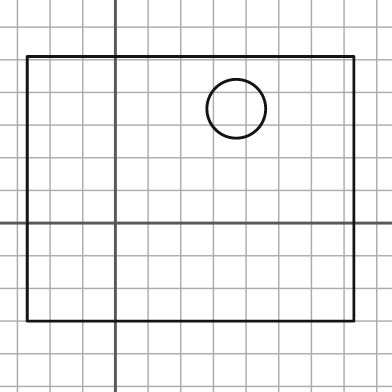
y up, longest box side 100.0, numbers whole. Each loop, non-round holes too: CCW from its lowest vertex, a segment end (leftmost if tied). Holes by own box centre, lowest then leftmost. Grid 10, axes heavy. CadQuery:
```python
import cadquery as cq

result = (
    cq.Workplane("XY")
    .moveTo(-27.0, -30.0)
    .lineTo(73.0, -30.0)
    .lineTo(73.0, 51.0)
    .lineTo(-27.0, 51.0)
    .close()
    .moveTo(37.0, 35.0)
    .circle(9.0)
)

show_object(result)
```